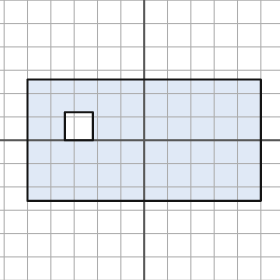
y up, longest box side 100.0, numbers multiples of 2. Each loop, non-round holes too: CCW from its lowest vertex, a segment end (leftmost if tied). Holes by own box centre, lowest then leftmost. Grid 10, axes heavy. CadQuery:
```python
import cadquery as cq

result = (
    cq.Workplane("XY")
    .moveTo(-50.0, -26.0)
    .lineTo(50.0, -26.0)
    .lineTo(50.0, 26.0)
    .lineTo(-50.0, 26.0)
    .close()
    .moveTo(-34.0, 0.0)
    .lineTo(-22.0, 0.0)
    .lineTo(-22.0, 12.0)
    .lineTo(-34.0, 12.0)
    .close()
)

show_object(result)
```